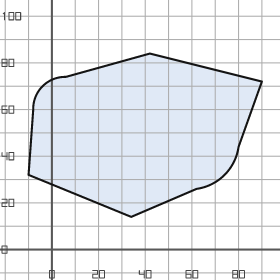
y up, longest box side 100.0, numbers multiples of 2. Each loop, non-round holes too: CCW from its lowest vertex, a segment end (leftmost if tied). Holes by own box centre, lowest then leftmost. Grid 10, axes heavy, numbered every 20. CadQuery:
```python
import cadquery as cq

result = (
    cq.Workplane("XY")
    .moveTo(34.0, 14.0)
    .lineTo(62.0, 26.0)
    .threePointArc((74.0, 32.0), (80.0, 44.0))
    .lineTo(90.0, 72.0)
    .lineTo(42.0, 84.0)
    .lineTo(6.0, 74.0)
    .threePointArc((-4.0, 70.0), (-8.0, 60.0))
    .lineTo(-10.0, 32.0)
    .close()
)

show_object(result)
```